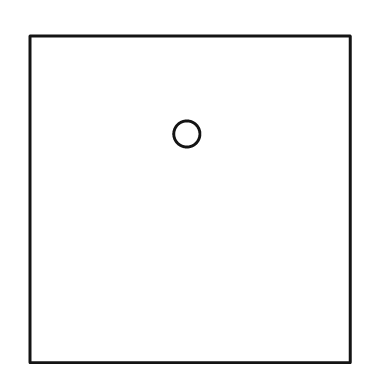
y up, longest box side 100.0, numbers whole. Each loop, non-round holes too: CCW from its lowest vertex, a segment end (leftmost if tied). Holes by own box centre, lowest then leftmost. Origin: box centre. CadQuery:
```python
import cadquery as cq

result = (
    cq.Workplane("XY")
    .moveTo(-49.0, -50.0)
    .lineTo(49.0, -50.0)
    .lineTo(49.0, 50.0)
    .lineTo(-49.0, 50.0)
    .close()
    .moveTo(-1.0, 20.0)
    .circle(4.0)
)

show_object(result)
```